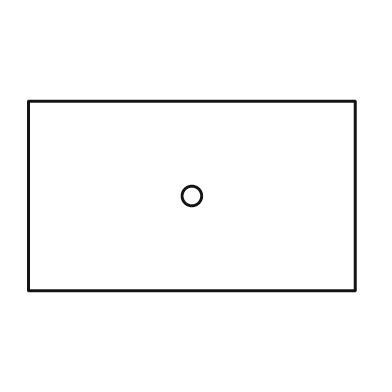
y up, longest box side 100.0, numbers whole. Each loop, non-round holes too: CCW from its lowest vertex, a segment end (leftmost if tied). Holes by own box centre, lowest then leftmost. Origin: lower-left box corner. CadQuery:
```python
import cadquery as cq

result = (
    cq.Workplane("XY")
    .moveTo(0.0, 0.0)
    .lineTo(100.0, 0.0)
    .lineTo(100.0, 58.0)
    .lineTo(0.0, 58.0)
    .close()
    .moveTo(50.0, 29.0)
    .circle(3.0)
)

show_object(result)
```